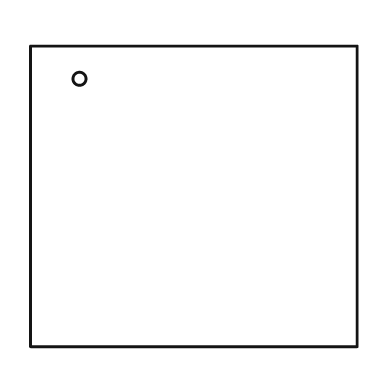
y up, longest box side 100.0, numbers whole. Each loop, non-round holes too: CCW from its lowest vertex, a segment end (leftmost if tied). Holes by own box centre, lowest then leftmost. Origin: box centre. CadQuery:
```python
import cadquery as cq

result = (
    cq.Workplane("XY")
    .moveTo(-50.0, -46.0)
    .lineTo(50.0, -46.0)
    .lineTo(50.0, 46.0)
    .lineTo(-50.0, 46.0)
    .close()
    .moveTo(-35.0, 36.0)
    .circle(2.0)
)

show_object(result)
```